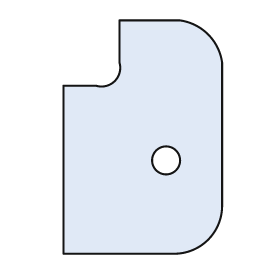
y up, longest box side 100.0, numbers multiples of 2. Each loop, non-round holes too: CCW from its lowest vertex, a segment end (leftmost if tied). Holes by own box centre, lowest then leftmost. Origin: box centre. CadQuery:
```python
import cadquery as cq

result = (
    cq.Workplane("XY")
    .moveTo(-34.0, -50.0)
    .lineTo(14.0, -50.0)
    .threePointArc((28.0, -44.0), (34.0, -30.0))
    .lineTo(34.0, 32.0)
    .threePointArc((28.0, 44.0), (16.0, 50.0))
    .lineTo(-10.0, 50.0)
    .lineTo(-10.0, 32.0)
    .threePointArc((-12.0, 24.0), (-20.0, 22.0))
    .lineTo(-34.0, 22.0)
    .close()
    .moveTo(10.0, -10.0)
    .circle(6.0)
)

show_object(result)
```